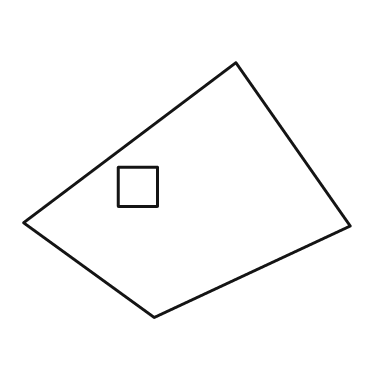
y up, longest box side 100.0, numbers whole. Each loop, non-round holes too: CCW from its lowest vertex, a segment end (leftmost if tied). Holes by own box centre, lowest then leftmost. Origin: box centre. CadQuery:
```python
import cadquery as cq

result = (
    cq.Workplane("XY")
    .moveTo(-10.0, -39.0)
    .lineTo(50.0, -11.0)
    .lineTo(15.0, 39.0)
    .lineTo(-50.0, -10.0)
    .close()
    .moveTo(-21.0, -5.0)
    .lineTo(-9.0, -5.0)
    .lineTo(-9.0, 7.0)
    .lineTo(-21.0, 7.0)
    .close()
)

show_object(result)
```